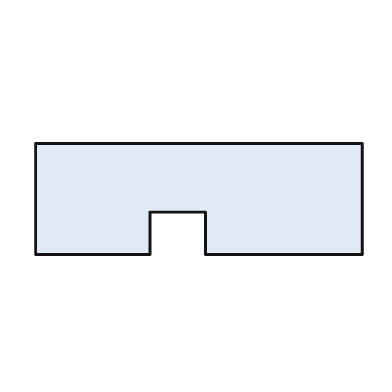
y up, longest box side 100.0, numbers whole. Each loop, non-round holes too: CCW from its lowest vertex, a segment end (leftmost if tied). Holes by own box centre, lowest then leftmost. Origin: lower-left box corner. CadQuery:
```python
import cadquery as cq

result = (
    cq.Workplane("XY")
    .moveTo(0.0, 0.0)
    .lineTo(35.0, 0.0)
    .lineTo(35.0, 13.0)
    .lineTo(52.0, 13.0)
    .lineTo(52.0, 0.0)
    .lineTo(100.0, 0.0)
    .lineTo(100.0, 34.0)
    .lineTo(0.0, 34.0)
    .close()
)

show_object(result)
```